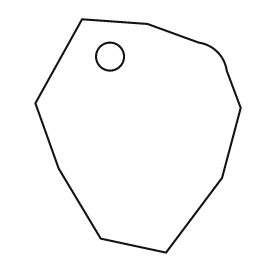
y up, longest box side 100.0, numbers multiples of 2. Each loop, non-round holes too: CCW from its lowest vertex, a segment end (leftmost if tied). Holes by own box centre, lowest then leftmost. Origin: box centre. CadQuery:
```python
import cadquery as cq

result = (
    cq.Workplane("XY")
    .moveTo(12.0, -50.0)
    .lineTo(36.0, -18.0)
    .lineTo(44.0, 12.0)
    .lineTo(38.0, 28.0)
    .threePointArc((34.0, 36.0), (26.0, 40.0))
    .lineTo(4.0, 48.0)
    .lineTo(-24.0, 50.0)
    .lineTo(-44.0, 14.0)
    .lineTo(-34.0, -14.0)
    .lineTo(-16.0, -44.0)
    .close()
    .moveTo(-12.0, 34.0)
    .circle(6.0)
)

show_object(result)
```